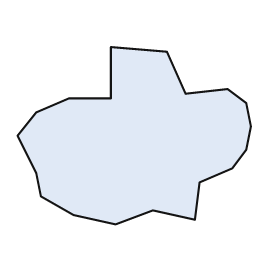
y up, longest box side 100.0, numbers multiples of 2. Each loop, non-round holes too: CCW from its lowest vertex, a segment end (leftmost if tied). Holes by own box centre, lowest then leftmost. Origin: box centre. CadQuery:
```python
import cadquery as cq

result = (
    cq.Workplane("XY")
    .moveTo(-8.0, -38.0)
    .lineTo(8.0, -32.0)
    .lineTo(26.0, -36.0)
    .lineTo(28.0, -20.0)
    .lineTo(42.0, -14.0)
    .lineTo(48.0, -6.0)
    .lineTo(50.0, 4.0)
    .lineTo(48.0, 14.0)
    .lineTo(40.0, 20.0)
    .lineTo(22.0, 18.0)
    .lineTo(14.0, 36.0)
    .lineTo(-10.0, 38.0)
    .lineTo(-10.0, 16.0)
    .lineTo(-28.0, 16.0)
    .lineTo(-42.0, 10.0)
    .lineTo(-50.0, 0.0)
    .lineTo(-42.0, -16.0)
    .lineTo(-40.0, -26.0)
    .lineTo(-26.0, -34.0)
    .close()
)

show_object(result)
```